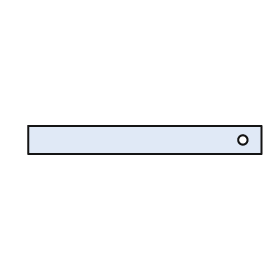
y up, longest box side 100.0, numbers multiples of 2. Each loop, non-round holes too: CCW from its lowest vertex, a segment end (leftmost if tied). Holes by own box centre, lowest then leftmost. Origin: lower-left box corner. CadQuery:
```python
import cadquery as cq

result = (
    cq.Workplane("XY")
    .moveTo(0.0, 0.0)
    .lineTo(100.0, 0.0)
    .lineTo(100.0, 12.0)
    .lineTo(0.0, 12.0)
    .close()
    .moveTo(92.0, 6.0)
    .circle(2.0)
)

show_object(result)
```